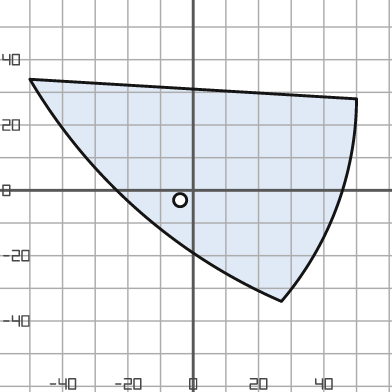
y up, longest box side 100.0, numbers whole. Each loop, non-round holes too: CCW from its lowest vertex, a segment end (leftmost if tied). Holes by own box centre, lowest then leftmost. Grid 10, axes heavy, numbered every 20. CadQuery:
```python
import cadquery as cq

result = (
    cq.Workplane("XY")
    .moveTo(27.0, -34.0)
    .threePointArc((44.0, -5.0), (50.0, 28.0))
    .lineTo(-50.0, 34.0)
    .threePointArc((-17.0, -6.0), (27.0, -34.0))
    .close()
    .moveTo(-4.0, -3.0)
    .circle(2.0)
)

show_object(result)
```